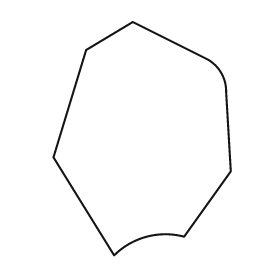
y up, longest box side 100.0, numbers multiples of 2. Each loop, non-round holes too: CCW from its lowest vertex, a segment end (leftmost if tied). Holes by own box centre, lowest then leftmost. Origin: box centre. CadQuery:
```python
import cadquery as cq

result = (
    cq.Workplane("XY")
    .moveTo(-12.0, -50.0)
    .threePointArc((2.0, -42.0), (18.0, -42.0))
    .lineTo(38.0, -14.0)
    .lineTo(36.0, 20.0)
    .threePointArc((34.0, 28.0), (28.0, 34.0))
    .lineTo(-4.0, 50.0)
    .lineTo(-24.0, 38.0)
    .lineTo(-38.0, -8.0)
    .close()
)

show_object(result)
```